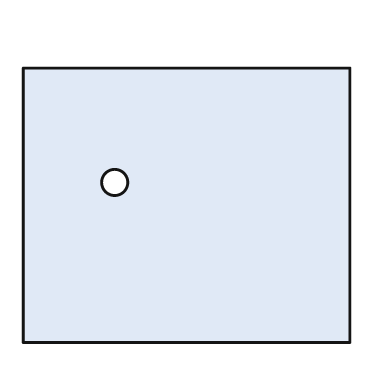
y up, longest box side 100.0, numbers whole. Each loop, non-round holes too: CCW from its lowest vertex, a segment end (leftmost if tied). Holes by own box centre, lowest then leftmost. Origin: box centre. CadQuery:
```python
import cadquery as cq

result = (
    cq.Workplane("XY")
    .moveTo(-50.0, -42.0)
    .lineTo(50.0, -42.0)
    .lineTo(50.0, 42.0)
    .lineTo(-50.0, 42.0)
    .close()
    .moveTo(-22.0, 7.0)
    .circle(4.0)
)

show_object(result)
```